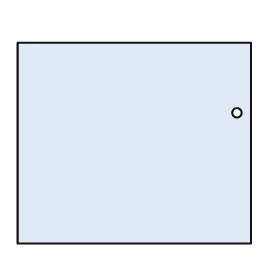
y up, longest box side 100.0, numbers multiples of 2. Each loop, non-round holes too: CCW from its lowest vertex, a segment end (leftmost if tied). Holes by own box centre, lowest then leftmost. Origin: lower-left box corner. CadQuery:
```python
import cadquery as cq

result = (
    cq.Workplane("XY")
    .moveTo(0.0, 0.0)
    .lineTo(100.0, 0.0)
    .lineTo(100.0, 86.0)
    .lineTo(0.0, 86.0)
    .close()
    .moveTo(94.0, 56.0)
    .circle(2.0)
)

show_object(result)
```